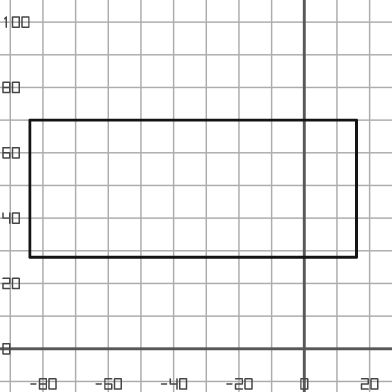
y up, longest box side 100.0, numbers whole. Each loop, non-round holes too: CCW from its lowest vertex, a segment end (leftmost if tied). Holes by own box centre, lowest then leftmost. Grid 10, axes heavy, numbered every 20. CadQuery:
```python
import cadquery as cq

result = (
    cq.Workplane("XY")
    .moveTo(-84.0, 28.0)
    .lineTo(16.0, 28.0)
    .lineTo(16.0, 70.0)
    .lineTo(-84.0, 70.0)
    .close()
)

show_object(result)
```